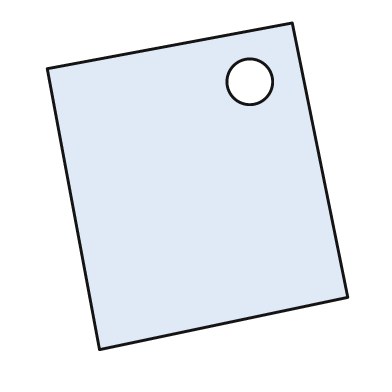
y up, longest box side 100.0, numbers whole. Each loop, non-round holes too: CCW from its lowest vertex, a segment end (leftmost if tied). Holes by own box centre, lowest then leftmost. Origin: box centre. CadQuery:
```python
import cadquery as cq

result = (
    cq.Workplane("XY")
    .moveTo(-30.0, -50.0)
    .lineTo(46.0, -34.0)
    .lineTo(29.0, 50.0)
    .lineTo(-46.0, 36.0)
    .close()
    .moveTo(16.0, 32.0)
    .circle(7.0)
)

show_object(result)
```